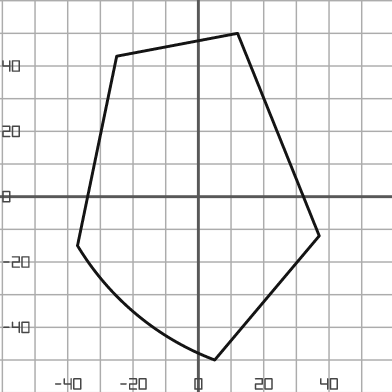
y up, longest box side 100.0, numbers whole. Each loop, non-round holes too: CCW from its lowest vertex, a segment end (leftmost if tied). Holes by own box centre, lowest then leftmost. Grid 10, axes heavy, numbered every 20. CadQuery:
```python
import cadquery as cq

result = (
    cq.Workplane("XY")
    .moveTo(5.0, -50.0)
    .lineTo(37.0, -12.0)
    .lineTo(12.0, 50.0)
    .lineTo(-25.0, 43.0)
    .lineTo(-37.0, -15.0)
    .threePointArc((-19.0, -36.0), (5.0, -50.0))
    .close()
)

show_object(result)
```